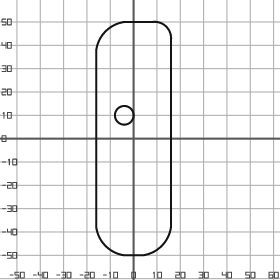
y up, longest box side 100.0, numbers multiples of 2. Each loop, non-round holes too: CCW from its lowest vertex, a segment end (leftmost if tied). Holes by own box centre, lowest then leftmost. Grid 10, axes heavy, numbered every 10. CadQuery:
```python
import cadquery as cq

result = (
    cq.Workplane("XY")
    .moveTo(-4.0, -50.0)
    .lineTo(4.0, -50.0)
    .threePointArc((12.0, -46.0), (16.0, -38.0))
    .lineTo(16.0, 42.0)
    .threePointArc((14.0, 48.0), (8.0, 50.0))
    .lineTo(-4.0, 50.0)
    .threePointArc((-12.0, 46.0), (-16.0, 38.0))
    .lineTo(-16.0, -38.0)
    .threePointArc((-12.0, -46.0), (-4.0, -50.0))
    .close()
    .moveTo(-4.0, 10.0)
    .circle(4.0)
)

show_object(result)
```